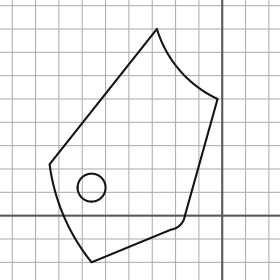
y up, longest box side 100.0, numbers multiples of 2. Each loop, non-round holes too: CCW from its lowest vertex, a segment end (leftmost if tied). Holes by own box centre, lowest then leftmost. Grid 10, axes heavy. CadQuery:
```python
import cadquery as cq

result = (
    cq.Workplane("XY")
    .moveTo(-56.0, -20.0)
    .lineTo(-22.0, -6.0)
    .threePointArc((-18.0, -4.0), (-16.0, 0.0))
    .lineTo(-2.0, 50.0)
    .threePointArc((-18.0, 62.0), (-28.0, 80.0))
    .lineTo(-74.0, 22.0)
    .threePointArc((-68.0, 0.0), (-56.0, -20.0))
    .close()
    .moveTo(-56.0, 12.0)
    .circle(6.0)
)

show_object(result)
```